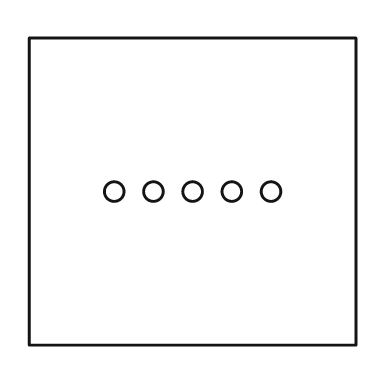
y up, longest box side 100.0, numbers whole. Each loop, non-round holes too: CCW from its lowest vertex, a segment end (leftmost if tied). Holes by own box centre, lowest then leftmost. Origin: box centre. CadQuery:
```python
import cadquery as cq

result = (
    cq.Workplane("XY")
    .moveTo(-50.0, -47.0)
    .lineTo(50.0, -47.0)
    .lineTo(50.0, 47.0)
    .lineTo(-50.0, 47.0)
    .close()
    .moveTo(-24.0, 0.0)
    .circle(3.0)
    .moveTo(-12.0, 0.0)
    .circle(3.0)
    .moveTo(0.0, 0.0)
    .circle(3.0)
    .moveTo(12.0, 0.0)
    .circle(3.0)
    .moveTo(24.0, 0.0)
    .circle(3.0)
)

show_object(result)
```